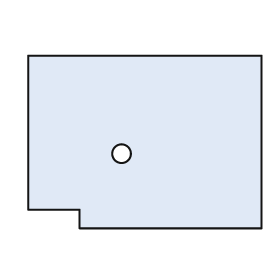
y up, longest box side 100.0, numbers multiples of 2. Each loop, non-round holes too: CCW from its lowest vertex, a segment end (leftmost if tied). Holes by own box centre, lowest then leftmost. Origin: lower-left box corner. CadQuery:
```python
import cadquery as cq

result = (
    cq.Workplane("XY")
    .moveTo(22.0, 0.0)
    .lineTo(100.0, 0.0)
    .lineTo(100.0, 74.0)
    .lineTo(0.0, 74.0)
    .lineTo(0.0, 8.0)
    .lineTo(22.0, 8.0)
    .close()
    .moveTo(40.0, 32.0)
    .circle(4.0)
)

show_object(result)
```